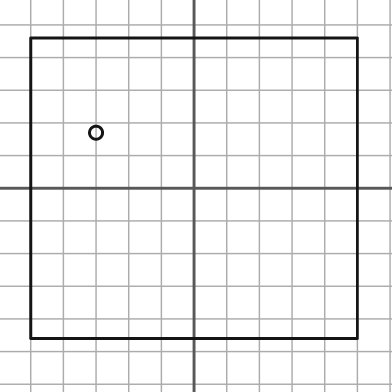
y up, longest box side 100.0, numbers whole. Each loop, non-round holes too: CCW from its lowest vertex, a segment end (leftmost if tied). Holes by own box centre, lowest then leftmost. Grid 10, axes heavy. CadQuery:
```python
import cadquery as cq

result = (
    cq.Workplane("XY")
    .moveTo(-50.0, -46.0)
    .lineTo(50.0, -46.0)
    .lineTo(50.0, 46.0)
    .lineTo(-50.0, 46.0)
    .close()
    .moveTo(-30.0, 17.0)
    .circle(2.0)
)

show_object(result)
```